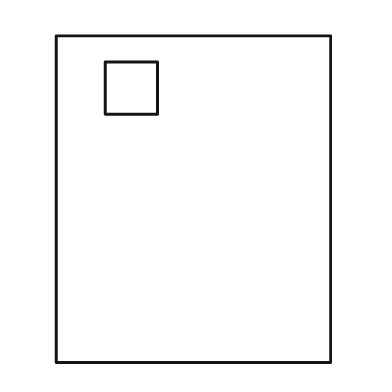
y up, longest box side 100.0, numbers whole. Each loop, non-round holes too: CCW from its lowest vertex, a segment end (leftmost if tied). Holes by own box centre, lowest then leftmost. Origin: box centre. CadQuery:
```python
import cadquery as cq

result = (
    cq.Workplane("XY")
    .moveTo(-42.0, -50.0)
    .lineTo(42.0, -50.0)
    .lineTo(42.0, 50.0)
    .lineTo(-42.0, 50.0)
    .close()
    .moveTo(-27.0, 26.0)
    .lineTo(-11.0, 26.0)
    .lineTo(-11.0, 42.0)
    .lineTo(-27.0, 42.0)
    .close()
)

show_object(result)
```